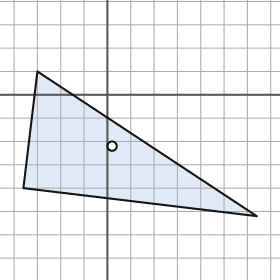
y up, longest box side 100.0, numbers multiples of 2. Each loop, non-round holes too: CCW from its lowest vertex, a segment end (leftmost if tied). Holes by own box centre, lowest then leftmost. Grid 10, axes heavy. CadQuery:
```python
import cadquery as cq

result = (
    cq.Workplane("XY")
    .moveTo(64.0, -52.0)
    .lineTo(-30.0, 10.0)
    .lineTo(-36.0, -40.0)
    .close()
    .moveTo(2.0, -22.0)
    .circle(2.0)
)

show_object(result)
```